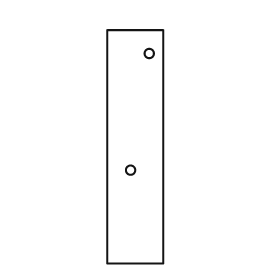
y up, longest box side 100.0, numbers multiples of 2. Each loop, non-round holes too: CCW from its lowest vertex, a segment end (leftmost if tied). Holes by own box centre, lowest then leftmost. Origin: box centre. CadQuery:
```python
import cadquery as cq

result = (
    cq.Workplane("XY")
    .moveTo(-12.0, -50.0)
    .lineTo(12.0, -50.0)
    .lineTo(12.0, 50.0)
    .lineTo(-12.0, 50.0)
    .close()
    .moveTo(-2.0, -10.0)
    .circle(2.0)
    .moveTo(6.0, 40.0)
    .circle(2.0)
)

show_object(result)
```